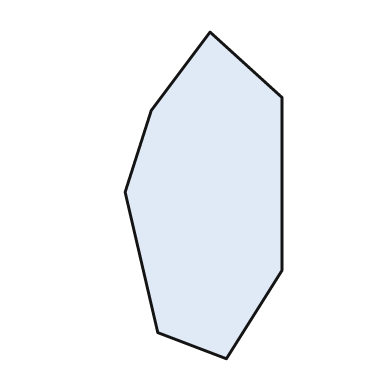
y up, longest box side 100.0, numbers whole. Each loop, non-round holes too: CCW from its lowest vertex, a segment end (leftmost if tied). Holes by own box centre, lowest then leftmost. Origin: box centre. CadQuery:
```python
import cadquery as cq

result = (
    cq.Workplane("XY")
    .moveTo(7.0, -50.0)
    .lineTo(24.0, -23.0)
    .lineTo(24.0, 30.0)
    .lineTo(2.0, 50.0)
    .lineTo(-16.0, 26.0)
    .lineTo(-24.0, 1.0)
    .lineTo(-14.0, -42.0)
    .close()
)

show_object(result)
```